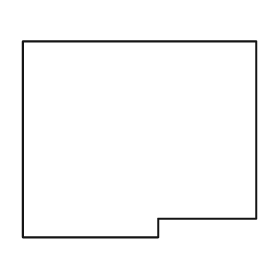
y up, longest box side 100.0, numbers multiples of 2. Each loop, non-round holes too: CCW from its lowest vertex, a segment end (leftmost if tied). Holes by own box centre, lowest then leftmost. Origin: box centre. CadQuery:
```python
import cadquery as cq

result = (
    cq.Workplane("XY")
    .moveTo(-50.0, -42.0)
    .lineTo(8.0, -42.0)
    .lineTo(8.0, -34.0)
    .lineTo(50.0, -34.0)
    .lineTo(50.0, 42.0)
    .lineTo(-50.0, 42.0)
    .close()
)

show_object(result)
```